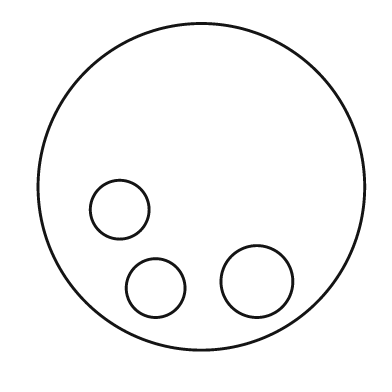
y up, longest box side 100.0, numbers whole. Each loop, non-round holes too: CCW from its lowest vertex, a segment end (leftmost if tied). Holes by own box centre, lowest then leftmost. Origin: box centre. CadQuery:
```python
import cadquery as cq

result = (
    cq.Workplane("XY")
    .moveTo(0.0, 0.0)
    .circle(50.0)
    .moveTo(-14.0, -31.0)
    .circle(9.0)
    .moveTo(17.0, -29.0)
    .circle(11.0)
    .moveTo(-25.0, -7.0)
    .circle(9.0)
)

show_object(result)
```